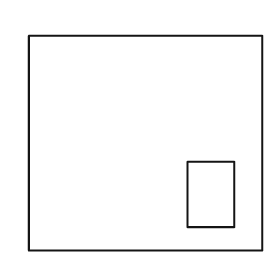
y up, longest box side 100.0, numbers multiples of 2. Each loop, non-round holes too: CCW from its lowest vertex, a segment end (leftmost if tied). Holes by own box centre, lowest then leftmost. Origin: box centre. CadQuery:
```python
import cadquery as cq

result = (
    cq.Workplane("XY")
    .moveTo(-50.0, -46.0)
    .lineTo(50.0, -46.0)
    .lineTo(50.0, 46.0)
    .lineTo(-50.0, 46.0)
    .close()
    .moveTo(18.0, -36.0)
    .lineTo(38.0, -36.0)
    .lineTo(38.0, -8.0)
    .lineTo(18.0, -8.0)
    .close()
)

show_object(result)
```